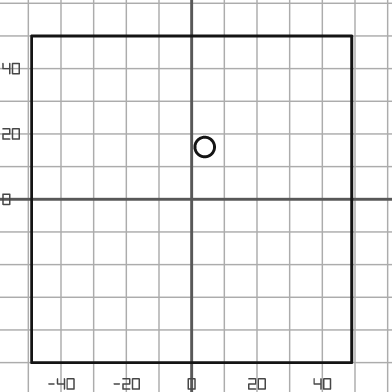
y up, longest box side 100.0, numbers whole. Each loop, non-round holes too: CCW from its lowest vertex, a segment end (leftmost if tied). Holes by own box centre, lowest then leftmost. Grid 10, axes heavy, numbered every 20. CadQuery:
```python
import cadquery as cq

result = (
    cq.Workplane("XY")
    .moveTo(-49.0, -50.0)
    .lineTo(49.0, -50.0)
    .lineTo(49.0, 50.0)
    .lineTo(-49.0, 50.0)
    .close()
    .moveTo(4.0, 16.0)
    .circle(3.0)
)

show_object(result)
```